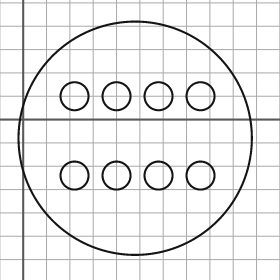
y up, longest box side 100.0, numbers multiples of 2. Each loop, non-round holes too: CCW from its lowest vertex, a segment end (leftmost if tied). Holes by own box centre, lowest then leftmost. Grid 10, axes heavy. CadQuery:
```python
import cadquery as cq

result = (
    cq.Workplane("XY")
    .moveTo(48.0, -8.0)
    .circle(50.0)
    .moveTo(22.0, -24.0)
    .circle(6.0)
    .moveTo(40.0, -24.0)
    .circle(6.0)
    .moveTo(58.0, -24.0)
    .circle(6.0)
    .moveTo(76.0, -24.0)
    .circle(6.0)
    .moveTo(22.0, 10.0)
    .circle(6.0)
    .moveTo(40.0, 10.0)
    .circle(6.0)
    .moveTo(58.0, 10.0)
    .circle(6.0)
    .moveTo(76.0, 10.0)
    .circle(6.0)
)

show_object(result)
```